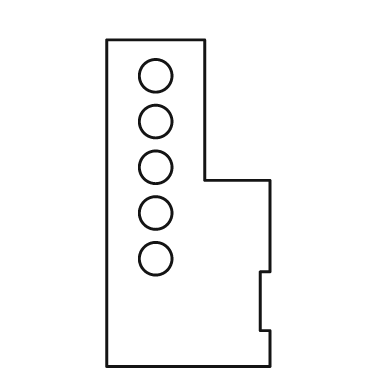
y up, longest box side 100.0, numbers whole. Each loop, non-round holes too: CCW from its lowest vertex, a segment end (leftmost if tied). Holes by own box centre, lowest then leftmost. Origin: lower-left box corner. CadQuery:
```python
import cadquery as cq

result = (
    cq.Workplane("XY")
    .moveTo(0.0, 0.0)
    .lineTo(50.0, 0.0)
    .lineTo(50.0, 11.0)
    .lineTo(47.0, 11.0)
    .lineTo(47.0, 29.0)
    .lineTo(50.0, 29.0)
    .lineTo(50.0, 57.0)
    .lineTo(30.0, 57.0)
    .lineTo(30.0, 100.0)
    .lineTo(0.0, 100.0)
    .close()
    .moveTo(15.0, 33.0)
    .circle(5.0)
    .moveTo(15.0, 47.0)
    .circle(5.0)
    .moveTo(15.0, 61.0)
    .circle(5.0)
    .moveTo(15.0, 75.0)
    .circle(5.0)
    .moveTo(15.0, 89.0)
    .circle(5.0)
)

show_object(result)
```